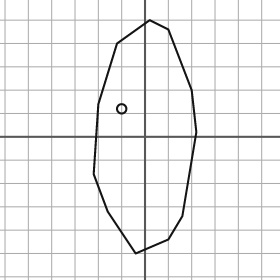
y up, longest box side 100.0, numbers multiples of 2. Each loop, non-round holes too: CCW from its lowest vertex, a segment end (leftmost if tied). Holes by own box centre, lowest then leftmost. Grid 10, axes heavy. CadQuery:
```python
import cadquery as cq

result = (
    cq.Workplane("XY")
    .moveTo(-4.0, -50.0)
    .lineTo(10.0, -44.0)
    .lineTo(16.0, -34.0)
    .lineTo(22.0, 2.0)
    .lineTo(20.0, 20.0)
    .lineTo(10.0, 46.0)
    .lineTo(2.0, 50.0)
    .lineTo(-12.0, 40.0)
    .lineTo(-20.0, 14.0)
    .lineTo(-22.0, -16.0)
    .lineTo(-16.0, -32.0)
    .close()
    .moveTo(-10.0, 12.0)
    .circle(2.0)
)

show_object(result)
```